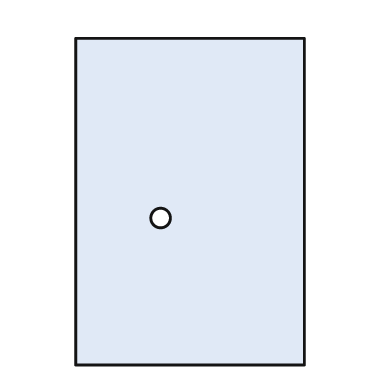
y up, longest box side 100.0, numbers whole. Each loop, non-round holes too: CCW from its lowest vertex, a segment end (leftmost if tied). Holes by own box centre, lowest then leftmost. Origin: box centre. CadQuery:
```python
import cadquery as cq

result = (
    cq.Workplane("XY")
    .moveTo(-35.0, -50.0)
    .lineTo(35.0, -50.0)
    .lineTo(35.0, 50.0)
    .lineTo(-35.0, 50.0)
    .close()
    .moveTo(-9.0, -5.0)
    .circle(3.0)
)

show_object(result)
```